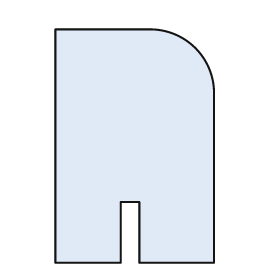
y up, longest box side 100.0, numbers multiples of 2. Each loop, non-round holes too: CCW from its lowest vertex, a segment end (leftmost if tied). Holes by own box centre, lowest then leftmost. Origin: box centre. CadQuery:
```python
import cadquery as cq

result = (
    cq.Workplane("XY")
    .moveTo(-34.0, -50.0)
    .lineTo(-6.0, -50.0)
    .lineTo(-6.0, -24.0)
    .lineTo(2.0, -24.0)
    .lineTo(2.0, -50.0)
    .lineTo(34.0, -50.0)
    .lineTo(34.0, 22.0)
    .threePointArc((26.0, 42.0), (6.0, 50.0))
    .lineTo(-34.0, 50.0)
    .close()
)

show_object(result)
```